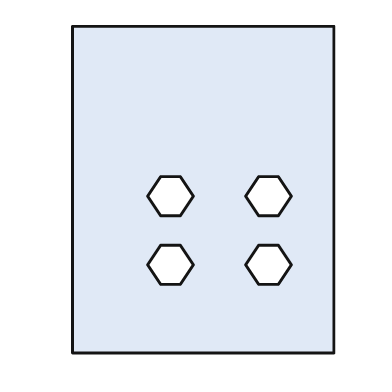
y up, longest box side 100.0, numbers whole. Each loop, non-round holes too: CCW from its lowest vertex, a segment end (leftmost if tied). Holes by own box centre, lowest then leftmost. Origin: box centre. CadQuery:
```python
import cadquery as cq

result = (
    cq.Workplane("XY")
    .moveTo(-40.0, -50.0)
    .lineTo(40.0, -50.0)
    .lineTo(40.0, 50.0)
    .lineTo(-40.0, 50.0)
    .close()
    .moveTo(-13.0, -29.0)
    .lineTo(-7.0, -29.0)
    .lineTo(-3.0, -23.0)
    .lineTo(-7.0, -17.0)
    .lineTo(-13.0, -17.0)
    .lineTo(-17.0, -23.0)
    .close()
    .moveTo(17.0, -29.0)
    .lineTo(23.0, -29.0)
    .lineTo(27.0, -23.0)
    .lineTo(23.0, -17.0)
    .lineTo(17.0, -17.0)
    .lineTo(13.0, -23.0)
    .close()
    .moveTo(-13.0, -8.0)
    .lineTo(-7.0, -8.0)
    .lineTo(-3.0, -2.0)
    .lineTo(-7.0, 4.0)
    .lineTo(-13.0, 4.0)
    .lineTo(-17.0, -2.0)
    .close()
    .moveTo(17.0, -8.0)
    .lineTo(23.0, -8.0)
    .lineTo(27.0, -2.0)
    .lineTo(23.0, 4.0)
    .lineTo(17.0, 4.0)
    .lineTo(13.0, -2.0)
    .close()
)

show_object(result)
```